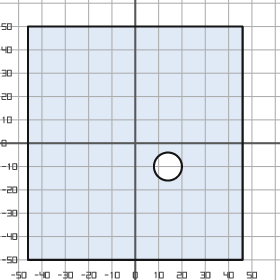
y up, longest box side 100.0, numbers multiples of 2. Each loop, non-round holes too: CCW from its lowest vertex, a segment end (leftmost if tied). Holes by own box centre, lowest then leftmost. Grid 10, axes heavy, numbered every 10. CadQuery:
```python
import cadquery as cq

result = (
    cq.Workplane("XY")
    .moveTo(-46.0, -50.0)
    .lineTo(46.0, -50.0)
    .lineTo(46.0, 50.0)
    .lineTo(-46.0, 50.0)
    .close()
    .moveTo(14.0, -10.0)
    .circle(6.0)
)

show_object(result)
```